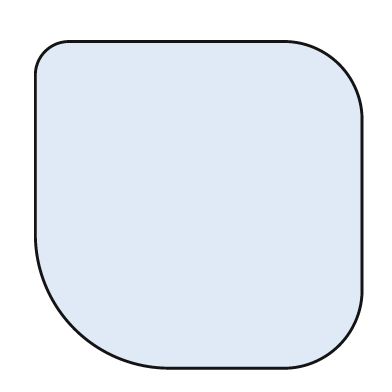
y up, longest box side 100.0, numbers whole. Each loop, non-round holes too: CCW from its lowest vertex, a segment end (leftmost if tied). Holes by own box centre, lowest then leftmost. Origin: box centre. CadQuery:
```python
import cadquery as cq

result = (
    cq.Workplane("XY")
    .moveTo(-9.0, -50.0)
    .lineTo(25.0, -50.0)
    .threePointArc((43.0, -43.0), (50.0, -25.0))
    .lineTo(50.0, 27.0)
    .threePointArc((43.0, 43.0), (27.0, 50.0))
    .lineTo(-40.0, 50.0)
    .threePointArc((-47.0, 47.0), (-50.0, 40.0))
    .lineTo(-50.0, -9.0)
    .threePointArc((-38.0, -38.0), (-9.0, -50.0))
    .close()
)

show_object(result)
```